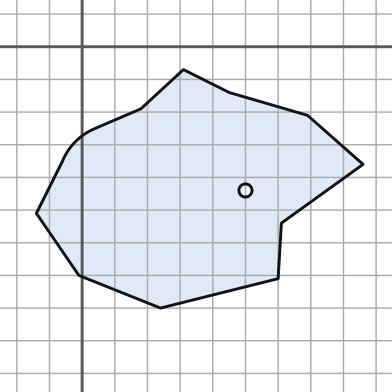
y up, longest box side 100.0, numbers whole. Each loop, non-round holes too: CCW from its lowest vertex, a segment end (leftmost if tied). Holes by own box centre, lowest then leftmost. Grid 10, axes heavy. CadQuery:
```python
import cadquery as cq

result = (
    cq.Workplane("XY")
    .moveTo(24.0, -80.0)
    .lineTo(60.0, -71.0)
    .lineTo(61.0, -54.0)
    .lineTo(86.0, -36.0)
    .lineTo(69.0, -21.0)
    .lineTo(45.0, -14.0)
    .lineTo(31.0, -7.0)
    .lineTo(18.0, -19.0)
    .lineTo(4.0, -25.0)
    .threePointArc((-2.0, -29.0), (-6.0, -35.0))
    .lineTo(-14.0, -51.0)
    .lineTo(-1.0, -70.0)
    .close()
    .moveTo(50.0, -44.0)
    .circle(2.0)
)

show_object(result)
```